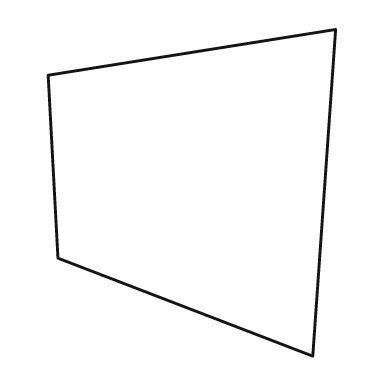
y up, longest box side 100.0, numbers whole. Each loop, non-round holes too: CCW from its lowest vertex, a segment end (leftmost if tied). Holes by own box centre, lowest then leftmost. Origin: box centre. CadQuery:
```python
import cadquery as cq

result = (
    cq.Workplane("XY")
    .moveTo(37.0, -50.0)
    .lineTo(44.0, 50.0)
    .lineTo(-44.0, 36.0)
    .lineTo(-41.0, -20.0)
    .close()
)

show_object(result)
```